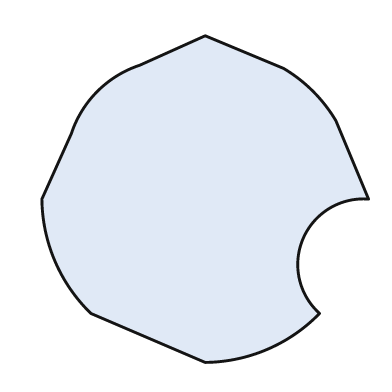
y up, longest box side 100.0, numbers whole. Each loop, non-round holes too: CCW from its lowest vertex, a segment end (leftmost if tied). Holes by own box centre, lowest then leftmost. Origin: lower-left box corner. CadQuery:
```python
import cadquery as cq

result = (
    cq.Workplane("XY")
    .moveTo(50.0, 0.0)
    .threePointArc((69.0, 4.0), (85.0, 15.0))
    .threePointArc((80.0, 38.0), (100.0, 50.0))
    .lineTo(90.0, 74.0)
    .threePointArc((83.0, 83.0), (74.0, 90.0))
    .lineTo(50.0, 100.0)
    .lineTo(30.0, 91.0)
    .threePointArc((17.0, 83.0), (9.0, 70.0))
    .lineTo(0.0, 50.0)
    .threePointArc((4.0, 31.0), (15.0, 15.0))
    .close()
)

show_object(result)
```